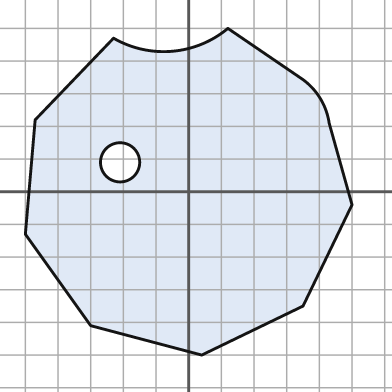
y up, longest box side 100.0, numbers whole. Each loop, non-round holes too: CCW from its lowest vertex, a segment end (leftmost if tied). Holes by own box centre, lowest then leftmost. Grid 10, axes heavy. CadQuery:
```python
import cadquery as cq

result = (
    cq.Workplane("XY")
    .moveTo(4.0, -50.0)
    .lineTo(35.0, -35.0)
    .lineTo(50.0, -4.0)
    .lineTo(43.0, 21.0)
    .threePointArc((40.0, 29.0), (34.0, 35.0))
    .lineTo(12.0, 50.0)
    .threePointArc((-5.0, 43.0), (-23.0, 47.0))
    .lineTo(-47.0, 22.0)
    .lineTo(-50.0, -13.0)
    .lineTo(-30.0, -41.0)
    .close()
    .moveTo(-21.0, 9.0)
    .circle(6.0)
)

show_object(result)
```